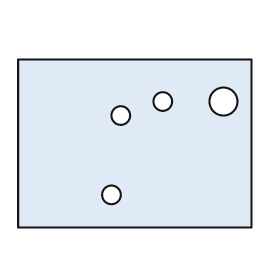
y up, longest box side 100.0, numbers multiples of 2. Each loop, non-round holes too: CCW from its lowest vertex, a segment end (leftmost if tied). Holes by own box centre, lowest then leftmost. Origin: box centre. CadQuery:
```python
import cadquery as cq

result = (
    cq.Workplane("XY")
    .moveTo(-50.0, -36.0)
    .lineTo(50.0, -36.0)
    .lineTo(50.0, 36.0)
    .lineTo(-50.0, 36.0)
    .close()
    .moveTo(-10.0, -22.0)
    .circle(4.0)
    .moveTo(-6.0, 12.0)
    .circle(4.0)
    .moveTo(12.0, 18.0)
    .circle(4.0)
    .moveTo(38.0, 18.0)
    .circle(6.0)
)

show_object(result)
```